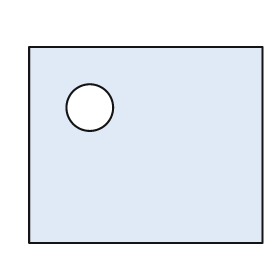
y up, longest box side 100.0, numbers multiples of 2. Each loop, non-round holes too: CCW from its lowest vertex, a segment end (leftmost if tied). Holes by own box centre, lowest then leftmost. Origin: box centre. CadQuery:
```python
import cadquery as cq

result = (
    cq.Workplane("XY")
    .moveTo(-50.0, -42.0)
    .lineTo(50.0, -42.0)
    .lineTo(50.0, 42.0)
    .lineTo(-50.0, 42.0)
    .close()
    .moveTo(-24.0, 16.0)
    .circle(10.0)
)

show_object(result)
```